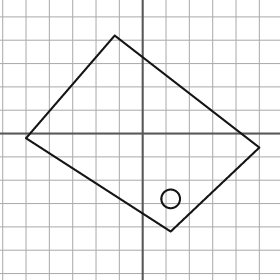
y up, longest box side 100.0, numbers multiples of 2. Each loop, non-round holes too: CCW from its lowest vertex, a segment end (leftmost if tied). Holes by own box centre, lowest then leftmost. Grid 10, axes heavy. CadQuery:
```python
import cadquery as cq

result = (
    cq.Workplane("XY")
    .moveTo(12.0, -42.0)
    .lineTo(50.0, -6.0)
    .lineTo(-12.0, 42.0)
    .lineTo(-50.0, -2.0)
    .close()
    .moveTo(12.0, -28.0)
    .circle(4.0)
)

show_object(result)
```